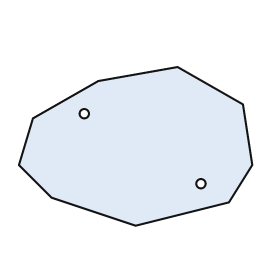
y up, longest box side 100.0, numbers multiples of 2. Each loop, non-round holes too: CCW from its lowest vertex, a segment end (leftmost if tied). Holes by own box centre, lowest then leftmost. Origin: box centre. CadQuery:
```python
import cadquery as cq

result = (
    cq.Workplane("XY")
    .moveTo(0.0, -34.0)
    .lineTo(40.0, -24.0)
    .lineTo(50.0, -8.0)
    .lineTo(46.0, 18.0)
    .lineTo(18.0, 34.0)
    .lineTo(-16.0, 28.0)
    .lineTo(-44.0, 12.0)
    .lineTo(-50.0, -8.0)
    .lineTo(-36.0, -22.0)
    .close()
    .moveTo(28.0, -16.0)
    .circle(2.0)
    .moveTo(-22.0, 14.0)
    .circle(2.0)
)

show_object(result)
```